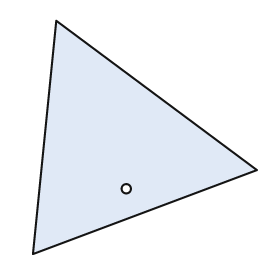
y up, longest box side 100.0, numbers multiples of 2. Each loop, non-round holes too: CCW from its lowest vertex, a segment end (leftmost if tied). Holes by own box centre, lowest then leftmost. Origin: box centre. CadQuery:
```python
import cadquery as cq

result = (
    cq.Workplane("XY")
    .moveTo(-48.0, -50.0)
    .lineTo(48.0, -14.0)
    .lineTo(-38.0, 50.0)
    .close()
    .moveTo(-8.0, -22.0)
    .circle(2.0)
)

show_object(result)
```